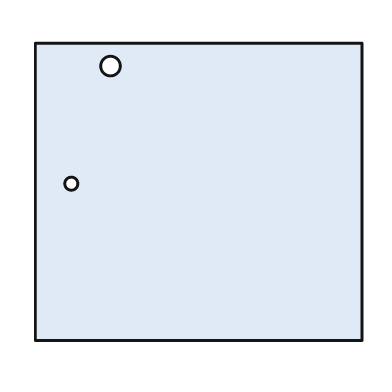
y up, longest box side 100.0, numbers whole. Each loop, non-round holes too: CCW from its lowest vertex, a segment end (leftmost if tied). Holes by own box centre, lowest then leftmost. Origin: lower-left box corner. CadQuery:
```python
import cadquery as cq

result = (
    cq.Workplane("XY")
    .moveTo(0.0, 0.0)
    .lineTo(100.0, 0.0)
    .lineTo(100.0, 91.0)
    .lineTo(0.0, 91.0)
    .close()
    .moveTo(11.0, 48.0)
    .circle(2.0)
    .moveTo(23.0, 84.0)
    .circle(3.0)
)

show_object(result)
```